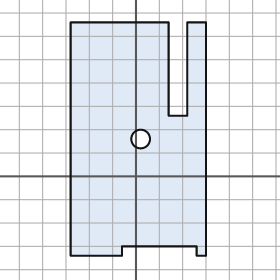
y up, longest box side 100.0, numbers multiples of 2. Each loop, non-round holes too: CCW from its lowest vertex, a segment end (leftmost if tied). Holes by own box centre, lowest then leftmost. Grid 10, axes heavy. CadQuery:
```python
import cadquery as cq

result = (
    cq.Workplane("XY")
    .moveTo(-28.0, -34.0)
    .lineTo(-6.0, -34.0)
    .lineTo(-6.0, -30.0)
    .lineTo(26.0, -30.0)
    .lineTo(26.0, -34.0)
    .lineTo(30.0, -34.0)
    .lineTo(30.0, 66.0)
    .lineTo(22.0, 66.0)
    .lineTo(22.0, 26.0)
    .lineTo(14.0, 26.0)
    .lineTo(14.0, 66.0)
    .lineTo(-28.0, 66.0)
    .close()
    .moveTo(2.0, 16.0)
    .circle(4.0)
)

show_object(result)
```